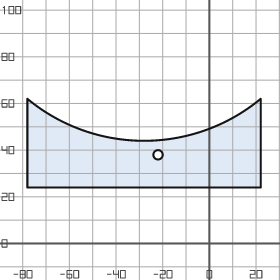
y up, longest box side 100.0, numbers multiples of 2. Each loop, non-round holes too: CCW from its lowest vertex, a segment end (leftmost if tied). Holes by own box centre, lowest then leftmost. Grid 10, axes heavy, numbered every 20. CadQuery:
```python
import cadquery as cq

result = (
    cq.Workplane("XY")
    .moveTo(-78.0, 24.0)
    .lineTo(22.0, 24.0)
    .lineTo(22.0, 62.0)
    .threePointArc((-28.0, 44.0), (-78.0, 62.0))
    .close()
    .moveTo(-22.0, 38.0)
    .circle(2.0)
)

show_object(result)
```